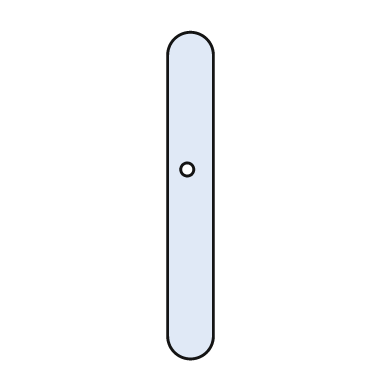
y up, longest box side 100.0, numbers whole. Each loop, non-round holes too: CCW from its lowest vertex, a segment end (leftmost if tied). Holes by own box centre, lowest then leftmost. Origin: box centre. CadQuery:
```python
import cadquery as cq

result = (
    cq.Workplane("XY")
    .moveTo(-7.0, -43.0)
    .threePointArc((0.0, -50.0), (7.0, -43.0))
    .lineTo(7.0, 43.0)
    .threePointArc((0.0, 50.0), (-7.0, 43.0))
    .close()
    .moveTo(-1.0, 8.0)
    .circle(2.0)
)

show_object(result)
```